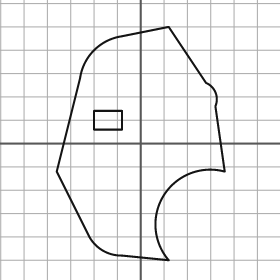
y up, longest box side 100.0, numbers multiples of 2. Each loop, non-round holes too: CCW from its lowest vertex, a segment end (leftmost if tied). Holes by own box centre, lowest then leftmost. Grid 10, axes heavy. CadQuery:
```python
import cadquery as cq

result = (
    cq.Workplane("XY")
    .moveTo(12.0, -50.0)
    .threePointArc((10.0, -22.0), (36.0, -12.0))
    .lineTo(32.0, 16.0)
    .threePointArc((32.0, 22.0), (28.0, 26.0))
    .lineTo(12.0, 50.0)
    .lineTo(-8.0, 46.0)
    .threePointArc((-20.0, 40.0), (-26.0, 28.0))
    .lineTo(-36.0, -12.0)
    .lineTo(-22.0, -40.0)
    .threePointArc((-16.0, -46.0), (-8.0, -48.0))
    .close()
    .moveTo(-20.0, 6.0)
    .lineTo(-8.0, 6.0)
    .lineTo(-8.0, 14.0)
    .lineTo(-20.0, 14.0)
    .close()
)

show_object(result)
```